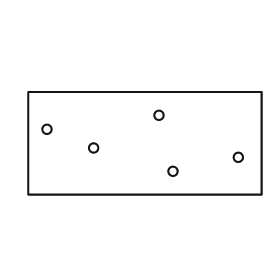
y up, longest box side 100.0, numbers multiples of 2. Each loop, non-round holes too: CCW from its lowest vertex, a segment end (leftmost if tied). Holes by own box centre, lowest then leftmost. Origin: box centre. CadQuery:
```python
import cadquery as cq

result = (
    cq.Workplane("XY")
    .moveTo(-50.0, -22.0)
    .lineTo(50.0, -22.0)
    .lineTo(50.0, 22.0)
    .lineTo(-50.0, 22.0)
    .close()
    .moveTo(12.0, -12.0)
    .circle(2.0)
    .moveTo(40.0, -6.0)
    .circle(2.0)
    .moveTo(-22.0, -2.0)
    .circle(2.0)
    .moveTo(-42.0, 6.0)
    .circle(2.0)
    .moveTo(6.0, 12.0)
    .circle(2.0)
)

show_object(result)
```